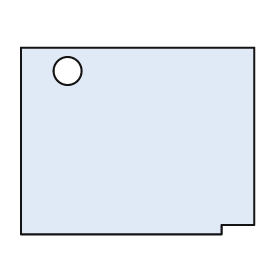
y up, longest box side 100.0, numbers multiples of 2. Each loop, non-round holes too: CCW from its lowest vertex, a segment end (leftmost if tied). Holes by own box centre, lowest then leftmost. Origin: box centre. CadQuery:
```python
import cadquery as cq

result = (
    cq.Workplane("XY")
    .moveTo(-50.0, -40.0)
    .lineTo(36.0, -40.0)
    .lineTo(36.0, -36.0)
    .lineTo(50.0, -36.0)
    .lineTo(50.0, 40.0)
    .lineTo(-50.0, 40.0)
    .close()
    .moveTo(-30.0, 30.0)
    .circle(6.0)
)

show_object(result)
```